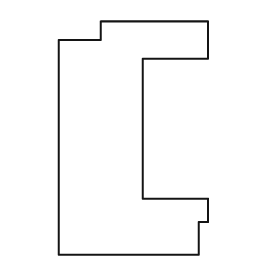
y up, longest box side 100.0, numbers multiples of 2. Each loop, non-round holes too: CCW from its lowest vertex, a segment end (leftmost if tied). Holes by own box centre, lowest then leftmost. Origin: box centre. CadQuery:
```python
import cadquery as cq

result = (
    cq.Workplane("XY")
    .moveTo(-32.0, -50.0)
    .lineTo(28.0, -50.0)
    .lineTo(28.0, -36.0)
    .lineTo(32.0, -36.0)
    .lineTo(32.0, -26.0)
    .lineTo(4.0, -26.0)
    .lineTo(4.0, 34.0)
    .lineTo(32.0, 34.0)
    .lineTo(32.0, 50.0)
    .lineTo(-14.0, 50.0)
    .lineTo(-14.0, 42.0)
    .lineTo(-32.0, 42.0)
    .close()
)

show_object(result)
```